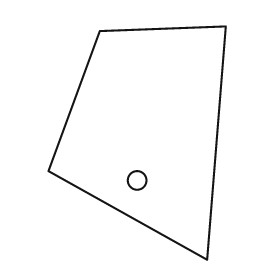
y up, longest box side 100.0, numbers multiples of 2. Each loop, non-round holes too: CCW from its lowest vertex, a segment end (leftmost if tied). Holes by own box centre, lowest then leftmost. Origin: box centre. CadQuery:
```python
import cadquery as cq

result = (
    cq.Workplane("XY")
    .moveTo(30.0, -50.0)
    .lineTo(38.0, 50.0)
    .lineTo(-16.0, 48.0)
    .lineTo(-38.0, -12.0)
    .close()
    .moveTo(0.0, -16.0)
    .circle(4.0)
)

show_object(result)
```